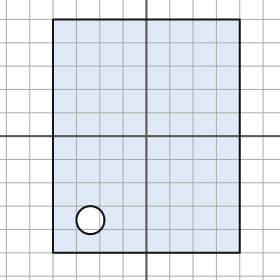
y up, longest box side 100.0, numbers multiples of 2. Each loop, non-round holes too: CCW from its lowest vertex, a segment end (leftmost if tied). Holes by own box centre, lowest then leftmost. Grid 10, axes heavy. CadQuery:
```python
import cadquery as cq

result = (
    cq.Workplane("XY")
    .moveTo(-40.0, -50.0)
    .lineTo(40.0, -50.0)
    .lineTo(40.0, 50.0)
    .lineTo(-40.0, 50.0)
    .close()
    .moveTo(-24.0, -36.0)
    .circle(6.0)
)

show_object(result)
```